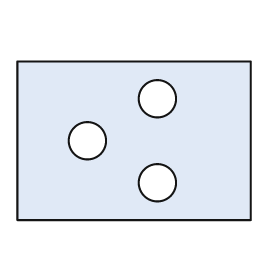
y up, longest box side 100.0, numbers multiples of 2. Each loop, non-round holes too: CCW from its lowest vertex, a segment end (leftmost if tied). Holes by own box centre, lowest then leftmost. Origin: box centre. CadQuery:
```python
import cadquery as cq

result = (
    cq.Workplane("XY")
    .moveTo(-50.0, -34.0)
    .lineTo(50.0, -34.0)
    .lineTo(50.0, 34.0)
    .lineTo(-50.0, 34.0)
    .close()
    .moveTo(10.0, -18.0)
    .circle(8.0)
    .moveTo(-20.0, 0.0)
    .circle(8.0)
    .moveTo(10.0, 18.0)
    .circle(8.0)
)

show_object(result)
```